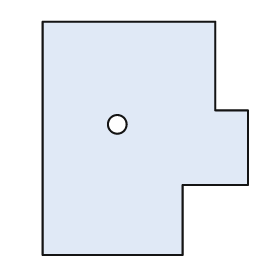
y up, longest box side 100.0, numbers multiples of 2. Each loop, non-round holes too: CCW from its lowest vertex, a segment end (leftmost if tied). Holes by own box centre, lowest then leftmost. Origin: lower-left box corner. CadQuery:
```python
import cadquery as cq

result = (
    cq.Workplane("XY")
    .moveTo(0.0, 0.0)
    .lineTo(60.0, 0.0)
    .lineTo(60.0, 30.0)
    .lineTo(88.0, 30.0)
    .lineTo(88.0, 62.0)
    .lineTo(74.0, 62.0)
    .lineTo(74.0, 100.0)
    .lineTo(0.0, 100.0)
    .close()
    .moveTo(32.0, 56.0)
    .circle(4.0)
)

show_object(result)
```